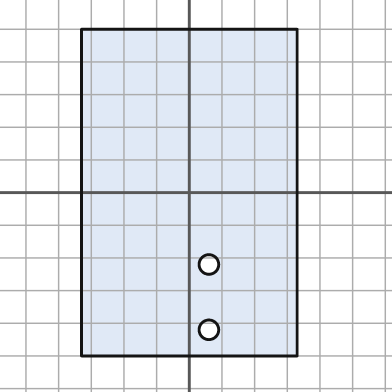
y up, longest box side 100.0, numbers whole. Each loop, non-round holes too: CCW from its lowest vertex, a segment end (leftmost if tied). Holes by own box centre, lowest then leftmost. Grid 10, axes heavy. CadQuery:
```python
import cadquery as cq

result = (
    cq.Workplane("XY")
    .moveTo(-33.0, -50.0)
    .lineTo(33.0, -50.0)
    .lineTo(33.0, 50.0)
    .lineTo(-33.0, 50.0)
    .close()
    .moveTo(6.0, -42.0)
    .circle(3.0)
    .moveTo(6.0, -22.0)
    .circle(3.0)
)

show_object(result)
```